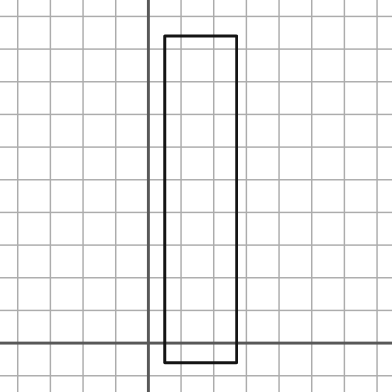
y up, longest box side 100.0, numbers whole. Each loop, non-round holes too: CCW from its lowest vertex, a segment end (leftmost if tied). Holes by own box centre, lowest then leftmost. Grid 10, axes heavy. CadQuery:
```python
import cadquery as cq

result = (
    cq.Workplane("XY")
    .moveTo(5.0, -6.0)
    .lineTo(27.0, -6.0)
    .lineTo(27.0, 94.0)
    .lineTo(5.0, 94.0)
    .close()
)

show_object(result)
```